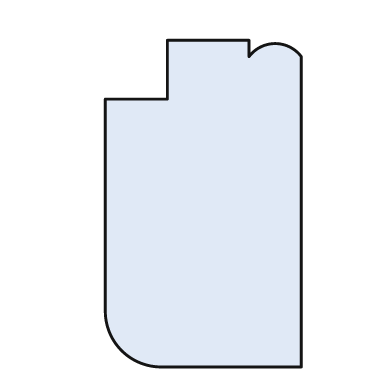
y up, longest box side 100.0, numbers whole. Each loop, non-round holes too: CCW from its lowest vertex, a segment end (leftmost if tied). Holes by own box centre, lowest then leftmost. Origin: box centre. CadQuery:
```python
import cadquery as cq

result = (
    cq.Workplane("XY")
    .moveTo(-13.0, -50.0)
    .lineTo(30.0, -50.0)
    .lineTo(30.0, 45.0)
    .threePointArc((22.0, 49.0), (14.0, 45.0))
    .lineTo(14.0, 50.0)
    .lineTo(-11.0, 50.0)
    .lineTo(-11.0, 32.0)
    .lineTo(-30.0, 32.0)
    .lineTo(-30.0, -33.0)
    .threePointArc((-25.0, -45.0), (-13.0, -50.0))
    .close()
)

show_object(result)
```